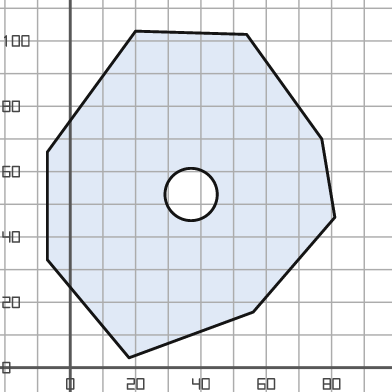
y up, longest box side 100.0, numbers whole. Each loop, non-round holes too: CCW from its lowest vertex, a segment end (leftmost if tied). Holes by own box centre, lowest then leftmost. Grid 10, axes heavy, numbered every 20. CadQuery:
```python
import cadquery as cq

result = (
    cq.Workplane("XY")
    .moveTo(18.0, 3.0)
    .lineTo(56.0, 17.0)
    .lineTo(81.0, 46.0)
    .lineTo(77.0, 70.0)
    .lineTo(54.0, 102.0)
    .lineTo(20.0, 103.0)
    .lineTo(-7.0, 66.0)
    .lineTo(-7.0, 33.0)
    .close()
    .moveTo(37.0, 53.0)
    .circle(8.0)
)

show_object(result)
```